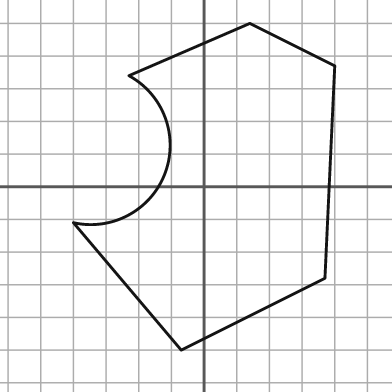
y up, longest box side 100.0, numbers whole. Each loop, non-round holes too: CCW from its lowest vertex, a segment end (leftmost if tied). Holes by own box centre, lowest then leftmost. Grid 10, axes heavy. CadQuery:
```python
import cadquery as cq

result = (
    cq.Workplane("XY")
    .moveTo(-7.0, -50.0)
    .lineTo(37.0, -28.0)
    .lineTo(40.0, 37.0)
    .lineTo(14.0, 50.0)
    .lineTo(-23.0, 34.0)
    .threePointArc((-12.0, 4.0), (-40.0, -11.0))
    .close()
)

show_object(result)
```